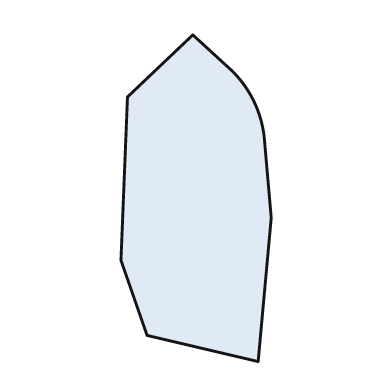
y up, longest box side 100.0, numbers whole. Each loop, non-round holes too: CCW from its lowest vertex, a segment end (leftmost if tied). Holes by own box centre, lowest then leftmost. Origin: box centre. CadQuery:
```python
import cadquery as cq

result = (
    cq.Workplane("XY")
    .moveTo(19.0, -50.0)
    .lineTo(23.0, -6.0)
    .lineTo(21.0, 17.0)
    .threePointArc((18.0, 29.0), (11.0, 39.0))
    .lineTo(-1.0, 50.0)
    .lineTo(-21.0, 31.0)
    .lineTo(-23.0, -19.0)
    .lineTo(-15.0, -42.0)
    .close()
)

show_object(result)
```